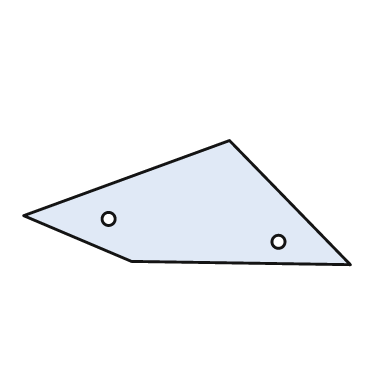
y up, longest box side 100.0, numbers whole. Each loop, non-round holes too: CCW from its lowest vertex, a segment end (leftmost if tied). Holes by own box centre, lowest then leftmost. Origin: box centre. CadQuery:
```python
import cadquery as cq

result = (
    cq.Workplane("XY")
    .moveTo(50.0, -19.0)
    .lineTo(13.0, 19.0)
    .lineTo(-50.0, -4.0)
    .lineTo(-17.0, -18.0)
    .close()
    .moveTo(28.0, -12.0)
    .circle(2.0)
    .moveTo(-24.0, -5.0)
    .circle(2.0)
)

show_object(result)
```